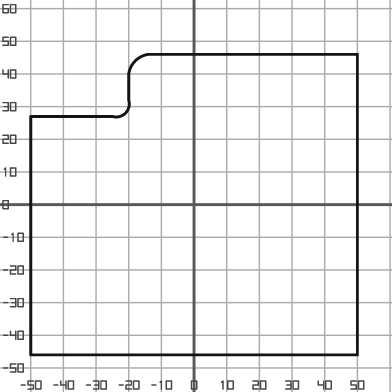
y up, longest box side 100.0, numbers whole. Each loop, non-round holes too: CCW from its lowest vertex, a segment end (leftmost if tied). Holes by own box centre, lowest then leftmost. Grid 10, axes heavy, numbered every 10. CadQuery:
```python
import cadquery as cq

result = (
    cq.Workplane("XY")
    .moveTo(-50.0, -46.0)
    .lineTo(50.0, -46.0)
    .lineTo(50.0, 46.0)
    .lineTo(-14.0, 46.0)
    .threePointArc((-18.0, 44.0), (-20.0, 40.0))
    .lineTo(-20.0, 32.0)
    .threePointArc((-21.0, 28.0), (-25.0, 27.0))
    .lineTo(-50.0, 27.0)
    .close()
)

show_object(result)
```